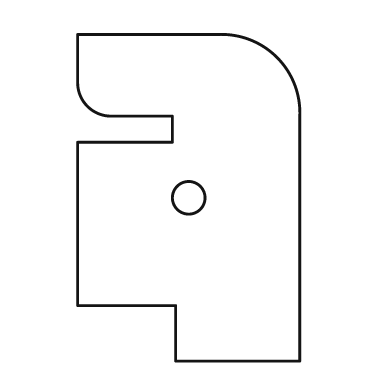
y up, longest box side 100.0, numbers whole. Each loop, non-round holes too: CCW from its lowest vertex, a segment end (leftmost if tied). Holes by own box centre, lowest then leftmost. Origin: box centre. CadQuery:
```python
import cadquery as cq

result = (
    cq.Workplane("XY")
    .moveTo(-4.0, -50.0)
    .lineTo(34.0, -50.0)
    .lineTo(34.0, 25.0)
    .threePointArc((27.0, 43.0), (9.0, 50.0))
    .lineTo(-34.0, 50.0)
    .lineTo(-34.0, 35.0)
    .threePointArc((-31.0, 28.0), (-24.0, 25.0))
    .lineTo(-5.0, 25.0)
    .lineTo(-5.0, 17.0)
    .lineTo(-34.0, 17.0)
    .lineTo(-34.0, -33.0)
    .lineTo(-4.0, -33.0)
    .close()
    .moveTo(0.0, 0.0)
    .circle(5.0)
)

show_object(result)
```